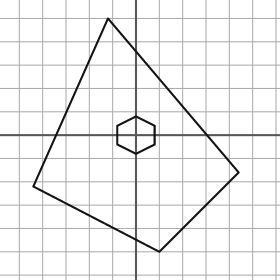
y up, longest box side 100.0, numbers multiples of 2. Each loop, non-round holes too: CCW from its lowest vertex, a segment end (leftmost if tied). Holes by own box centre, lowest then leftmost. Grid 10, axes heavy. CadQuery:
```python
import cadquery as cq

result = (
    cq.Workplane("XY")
    .moveTo(10.0, -50.0)
    .lineTo(44.0, -16.0)
    .lineTo(-12.0, 50.0)
    .lineTo(-44.0, -22.0)
    .close()
    .moveTo(0.0, -8.0)
    .lineTo(8.0, -4.0)
    .lineTo(8.0, 4.0)
    .lineTo(0.0, 8.0)
    .lineTo(-8.0, 4.0)
    .lineTo(-8.0, -4.0)
    .close()
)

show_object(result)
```